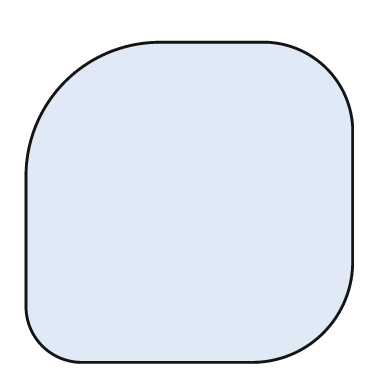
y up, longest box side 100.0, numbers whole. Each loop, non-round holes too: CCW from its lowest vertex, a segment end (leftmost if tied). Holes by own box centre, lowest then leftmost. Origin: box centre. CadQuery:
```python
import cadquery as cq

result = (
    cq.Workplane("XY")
    .moveTo(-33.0, -49.0)
    .lineTo(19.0, -49.0)
    .threePointArc((41.0, -40.0), (50.0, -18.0))
    .lineTo(50.0, 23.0)
    .threePointArc((42.0, 41.0), (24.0, 49.0))
    .lineTo(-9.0, 49.0)
    .threePointArc((-38.0, 37.0), (-50.0, 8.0))
    .lineTo(-50.0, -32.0)
    .threePointArc((-45.0, -44.0), (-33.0, -49.0))
    .close()
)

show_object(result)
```